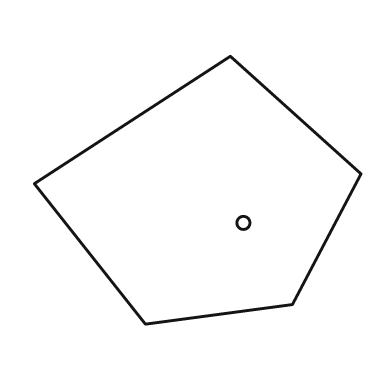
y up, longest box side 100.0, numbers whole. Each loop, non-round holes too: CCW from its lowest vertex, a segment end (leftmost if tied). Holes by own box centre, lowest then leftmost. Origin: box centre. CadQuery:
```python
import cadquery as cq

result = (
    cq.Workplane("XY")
    .moveTo(-16.0, -41.0)
    .lineTo(29.0, -35.0)
    .lineTo(50.0, 5.0)
    .lineTo(10.0, 41.0)
    .lineTo(-50.0, 2.0)
    .close()
    .moveTo(14.0, -10.0)
    .circle(2.0)
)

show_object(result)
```